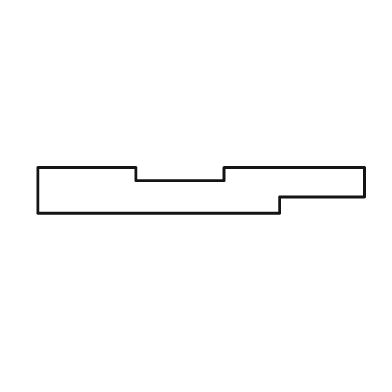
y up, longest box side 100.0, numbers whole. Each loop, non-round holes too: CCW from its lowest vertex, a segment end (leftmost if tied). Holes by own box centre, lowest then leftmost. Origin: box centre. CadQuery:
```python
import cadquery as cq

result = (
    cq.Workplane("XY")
    .moveTo(-50.0, -7.0)
    .lineTo(24.0, -7.0)
    .lineTo(24.0, -2.0)
    .lineTo(50.0, -2.0)
    .lineTo(50.0, 7.0)
    .lineTo(7.0, 7.0)
    .lineTo(7.0, 3.0)
    .lineTo(-20.0, 3.0)
    .lineTo(-20.0, 7.0)
    .lineTo(-50.0, 7.0)
    .close()
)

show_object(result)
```